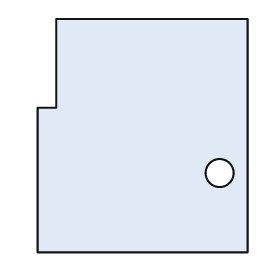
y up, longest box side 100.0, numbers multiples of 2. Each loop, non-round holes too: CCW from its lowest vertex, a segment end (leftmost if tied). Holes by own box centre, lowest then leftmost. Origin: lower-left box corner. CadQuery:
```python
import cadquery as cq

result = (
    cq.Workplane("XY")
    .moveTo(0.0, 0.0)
    .lineTo(90.0, 0.0)
    .lineTo(90.0, 100.0)
    .lineTo(8.0, 100.0)
    .lineTo(8.0, 62.0)
    .lineTo(0.0, 62.0)
    .close()
    .moveTo(78.0, 34.0)
    .circle(6.0)
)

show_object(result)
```